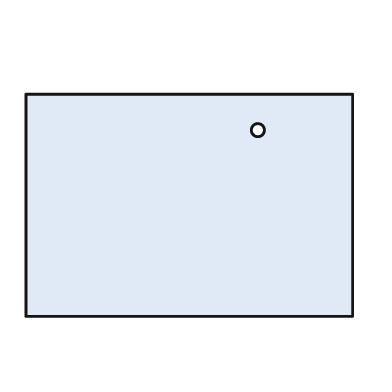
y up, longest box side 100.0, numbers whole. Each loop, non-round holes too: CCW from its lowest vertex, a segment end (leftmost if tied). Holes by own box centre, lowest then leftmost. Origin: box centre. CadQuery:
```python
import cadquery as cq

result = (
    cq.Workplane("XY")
    .moveTo(-50.0, -34.0)
    .lineTo(50.0, -34.0)
    .lineTo(50.0, 34.0)
    .lineTo(-50.0, 34.0)
    .close()
    .moveTo(21.0, 23.0)
    .circle(2.0)
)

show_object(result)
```